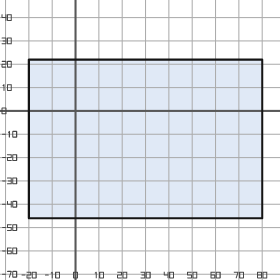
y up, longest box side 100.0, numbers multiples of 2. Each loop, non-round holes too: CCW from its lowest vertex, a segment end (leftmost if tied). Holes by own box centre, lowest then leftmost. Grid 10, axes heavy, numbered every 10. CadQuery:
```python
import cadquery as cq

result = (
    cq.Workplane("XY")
    .moveTo(-20.0, -46.0)
    .lineTo(80.0, -46.0)
    .lineTo(80.0, 22.0)
    .lineTo(-20.0, 22.0)
    .close()
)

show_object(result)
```